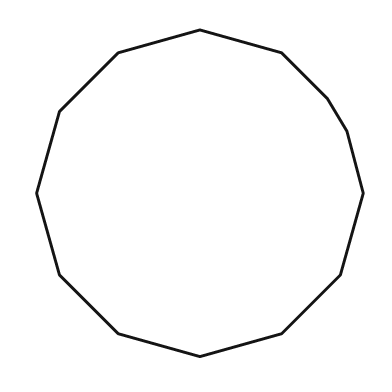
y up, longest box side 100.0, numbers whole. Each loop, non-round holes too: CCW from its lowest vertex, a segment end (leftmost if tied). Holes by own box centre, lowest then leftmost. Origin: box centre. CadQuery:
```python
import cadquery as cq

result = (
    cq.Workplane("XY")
    .moveTo(0.0, -50.0)
    .lineTo(25.0, -43.0)
    .lineTo(43.0, -25.0)
    .lineTo(50.0, 0.0)
    .lineTo(45.0, 19.0)
    .lineTo(39.0, 29.0)
    .lineTo(25.0, 43.0)
    .lineTo(0.0, 50.0)
    .lineTo(-25.0, 43.0)
    .lineTo(-43.0, 25.0)
    .lineTo(-50.0, 0.0)
    .lineTo(-43.0, -25.0)
    .lineTo(-25.0, -43.0)
    .close()
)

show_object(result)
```